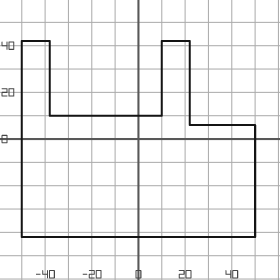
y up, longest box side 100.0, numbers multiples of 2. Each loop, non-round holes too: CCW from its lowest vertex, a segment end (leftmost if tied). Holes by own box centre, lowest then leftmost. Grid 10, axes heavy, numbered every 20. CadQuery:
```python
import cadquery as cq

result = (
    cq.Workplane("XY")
    .moveTo(-50.0, -42.0)
    .lineTo(50.0, -42.0)
    .lineTo(50.0, 6.0)
    .lineTo(22.0, 6.0)
    .lineTo(22.0, 42.0)
    .lineTo(10.0, 42.0)
    .lineTo(10.0, 10.0)
    .lineTo(-38.0, 10.0)
    .lineTo(-38.0, 42.0)
    .lineTo(-50.0, 42.0)
    .close()
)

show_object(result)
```